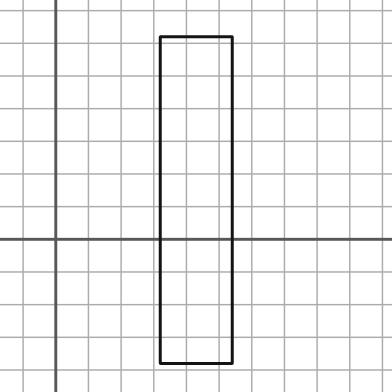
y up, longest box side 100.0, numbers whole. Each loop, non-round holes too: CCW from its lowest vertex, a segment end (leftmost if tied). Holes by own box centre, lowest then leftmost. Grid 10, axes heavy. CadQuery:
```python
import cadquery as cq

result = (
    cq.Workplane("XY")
    .moveTo(32.0, -38.0)
    .lineTo(54.0, -38.0)
    .lineTo(54.0, 62.0)
    .lineTo(32.0, 62.0)
    .close()
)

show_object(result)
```